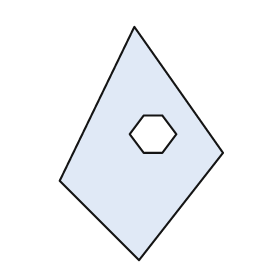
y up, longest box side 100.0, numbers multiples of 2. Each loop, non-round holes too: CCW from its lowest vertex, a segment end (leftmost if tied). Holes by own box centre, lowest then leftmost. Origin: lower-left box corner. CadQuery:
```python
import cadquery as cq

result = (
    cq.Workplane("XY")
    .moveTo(34.0, 0.0)
    .lineTo(70.0, 46.0)
    .lineTo(32.0, 100.0)
    .lineTo(0.0, 34.0)
    .close()
    .moveTo(36.0, 46.0)
    .lineTo(44.0, 46.0)
    .lineTo(50.0, 54.0)
    .lineTo(44.0, 62.0)
    .lineTo(36.0, 62.0)
    .lineTo(30.0, 54.0)
    .close()
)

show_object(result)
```